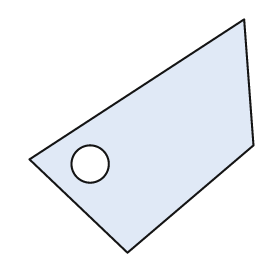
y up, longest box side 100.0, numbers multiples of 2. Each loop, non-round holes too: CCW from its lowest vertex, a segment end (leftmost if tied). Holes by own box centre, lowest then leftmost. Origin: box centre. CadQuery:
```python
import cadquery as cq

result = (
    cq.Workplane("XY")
    .moveTo(-6.0, -50.0)
    .lineTo(48.0, -4.0)
    .lineTo(44.0, 50.0)
    .lineTo(-48.0, -10.0)
    .close()
    .moveTo(-22.0, -12.0)
    .circle(8.0)
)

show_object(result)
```